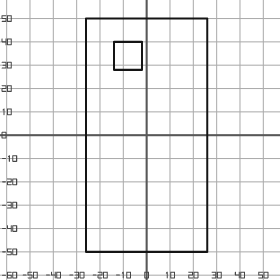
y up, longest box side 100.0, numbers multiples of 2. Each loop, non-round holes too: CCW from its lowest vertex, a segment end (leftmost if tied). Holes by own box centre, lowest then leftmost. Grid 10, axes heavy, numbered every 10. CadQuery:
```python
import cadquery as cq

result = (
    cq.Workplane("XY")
    .moveTo(-26.0, -50.0)
    .lineTo(26.0, -50.0)
    .lineTo(26.0, 50.0)
    .lineTo(-26.0, 50.0)
    .close()
    .moveTo(-14.0, 28.0)
    .lineTo(-2.0, 28.0)
    .lineTo(-2.0, 40.0)
    .lineTo(-14.0, 40.0)
    .close()
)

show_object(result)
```